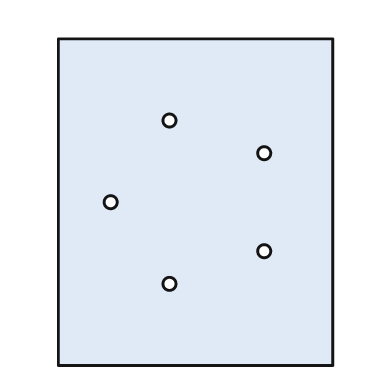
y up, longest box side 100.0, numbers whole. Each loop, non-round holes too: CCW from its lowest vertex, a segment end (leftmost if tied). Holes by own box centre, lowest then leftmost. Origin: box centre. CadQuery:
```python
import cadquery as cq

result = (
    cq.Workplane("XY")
    .moveTo(-42.0, -50.0)
    .lineTo(42.0, -50.0)
    .lineTo(42.0, 50.0)
    .lineTo(-42.0, 50.0)
    .close()
    .moveTo(-8.0, -25.0)
    .circle(2.0)
    .moveTo(21.0, -15.0)
    .circle(2.0)
    .moveTo(-26.0, 0.0)
    .circle(2.0)
    .moveTo(21.0, 15.0)
    .circle(2.0)
    .moveTo(-8.0, 25.0)
    .circle(2.0)
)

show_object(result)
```